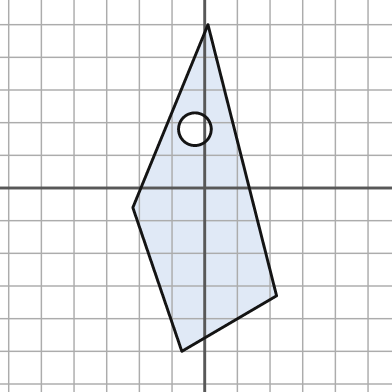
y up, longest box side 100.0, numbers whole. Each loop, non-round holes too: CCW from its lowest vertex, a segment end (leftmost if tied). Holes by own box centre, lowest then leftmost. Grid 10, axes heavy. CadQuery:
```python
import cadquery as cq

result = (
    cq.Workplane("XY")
    .moveTo(-7.0, -50.0)
    .lineTo(22.0, -33.0)
    .lineTo(1.0, 50.0)
    .lineTo(-22.0, -6.0)
    .close()
    .moveTo(-3.0, 18.0)
    .circle(5.0)
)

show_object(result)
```